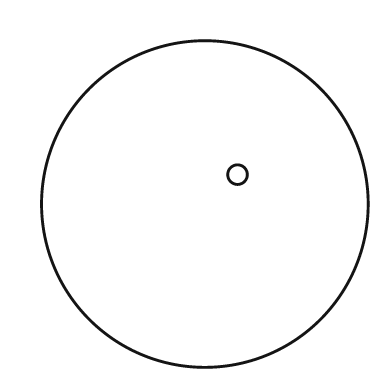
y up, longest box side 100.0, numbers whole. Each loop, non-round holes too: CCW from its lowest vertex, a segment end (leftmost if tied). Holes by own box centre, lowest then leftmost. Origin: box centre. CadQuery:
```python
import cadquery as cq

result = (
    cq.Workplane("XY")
    .moveTo(0.0, 0.0)
    .circle(50.0)
    .moveTo(10.0, 9.0)
    .circle(3.0)
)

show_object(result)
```